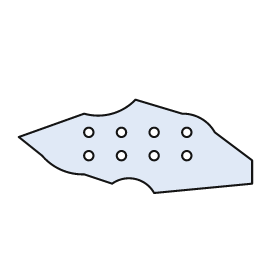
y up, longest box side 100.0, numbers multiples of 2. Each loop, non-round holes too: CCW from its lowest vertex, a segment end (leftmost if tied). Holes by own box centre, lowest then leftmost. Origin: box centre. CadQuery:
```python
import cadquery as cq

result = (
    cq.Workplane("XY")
    .moveTo(8.0, -20.0)
    .lineTo(50.0, -16.0)
    .lineTo(50.0, -6.0)
    .lineTo(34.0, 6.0)
    .threePointArc((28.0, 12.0), (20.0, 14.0))
    .lineTo(0.0, 20.0)
    .threePointArc((-10.0, 14.0), (-22.0, 14.0))
    .lineTo(-50.0, 4.0)
    .lineTo(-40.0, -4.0)
    .threePointArc((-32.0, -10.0), (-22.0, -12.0))
    .lineTo(-10.0, -16.0)
    .threePointArc((0.0, -14.0), (8.0, -20.0))
    .close()
    .moveTo(-20.0, -4.0)
    .circle(2.0)
    .moveTo(-6.0, -4.0)
    .circle(2.0)
    .moveTo(8.0, -4.0)
    .circle(2.0)
    .moveTo(22.0, -4.0)
    .circle(2.0)
    .moveTo(-20.0, 6.0)
    .circle(2.0)
    .moveTo(-6.0, 6.0)
    .circle(2.0)
    .moveTo(8.0, 6.0)
    .circle(2.0)
    .moveTo(22.0, 6.0)
    .circle(2.0)
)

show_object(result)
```